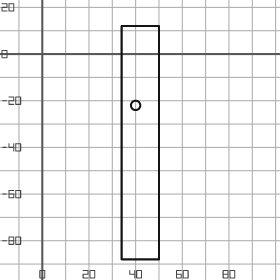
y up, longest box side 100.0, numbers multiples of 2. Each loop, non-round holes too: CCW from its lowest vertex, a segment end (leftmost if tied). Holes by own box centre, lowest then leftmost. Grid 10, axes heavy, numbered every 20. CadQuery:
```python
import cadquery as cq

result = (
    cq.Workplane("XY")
    .moveTo(34.0, -88.0)
    .lineTo(50.0, -88.0)
    .lineTo(50.0, 12.0)
    .lineTo(34.0, 12.0)
    .close()
    .moveTo(40.0, -22.0)
    .circle(2.0)
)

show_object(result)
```